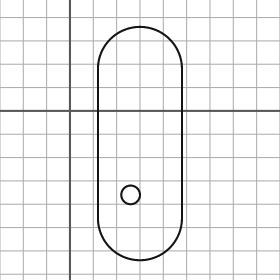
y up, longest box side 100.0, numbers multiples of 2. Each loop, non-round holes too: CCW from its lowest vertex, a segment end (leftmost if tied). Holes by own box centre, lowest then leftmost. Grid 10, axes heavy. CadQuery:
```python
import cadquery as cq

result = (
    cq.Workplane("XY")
    .moveTo(12.0, -46.0)
    .threePointArc((30.0, -64.0), (48.0, -46.0))
    .lineTo(48.0, 18.0)
    .threePointArc((30.0, 36.0), (12.0, 18.0))
    .close()
    .moveTo(26.0, -36.0)
    .circle(4.0)
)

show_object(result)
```